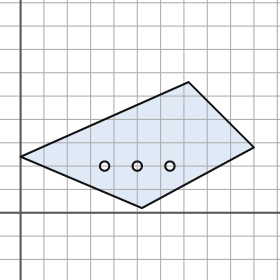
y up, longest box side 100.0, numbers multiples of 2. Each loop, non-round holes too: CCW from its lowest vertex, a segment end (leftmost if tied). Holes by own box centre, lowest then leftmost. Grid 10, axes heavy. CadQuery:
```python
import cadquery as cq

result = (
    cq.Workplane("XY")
    .moveTo(52.0, 2.0)
    .lineTo(100.0, 28.0)
    .lineTo(72.0, 56.0)
    .lineTo(0.0, 24.0)
    .close()
    .moveTo(36.0, 20.0)
    .circle(2.0)
    .moveTo(50.0, 20.0)
    .circle(2.0)
    .moveTo(64.0, 20.0)
    .circle(2.0)
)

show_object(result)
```